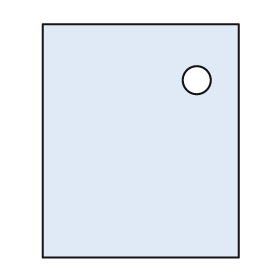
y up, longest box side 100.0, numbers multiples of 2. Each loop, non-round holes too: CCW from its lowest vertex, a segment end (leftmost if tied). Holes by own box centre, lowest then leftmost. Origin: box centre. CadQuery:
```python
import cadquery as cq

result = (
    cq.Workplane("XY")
    .moveTo(-42.0, -50.0)
    .lineTo(42.0, -50.0)
    .lineTo(42.0, 50.0)
    .lineTo(-42.0, 50.0)
    .close()
    .moveTo(24.0, 26.0)
    .circle(6.0)
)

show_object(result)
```